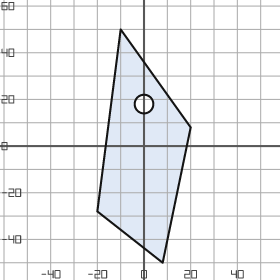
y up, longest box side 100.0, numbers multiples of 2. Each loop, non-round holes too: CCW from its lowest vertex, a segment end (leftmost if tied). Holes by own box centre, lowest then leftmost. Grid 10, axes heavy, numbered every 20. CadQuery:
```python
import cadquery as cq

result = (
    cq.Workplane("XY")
    .moveTo(8.0, -50.0)
    .lineTo(20.0, 8.0)
    .lineTo(-10.0, 50.0)
    .lineTo(-20.0, -28.0)
    .close()
    .moveTo(0.0, 18.0)
    .circle(4.0)
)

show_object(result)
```